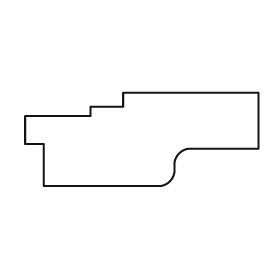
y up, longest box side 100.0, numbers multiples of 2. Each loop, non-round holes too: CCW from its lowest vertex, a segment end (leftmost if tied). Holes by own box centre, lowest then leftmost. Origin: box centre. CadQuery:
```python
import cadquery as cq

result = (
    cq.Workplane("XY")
    .moveTo(-42.0, -20.0)
    .lineTo(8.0, -20.0)
    .threePointArc((12.0, -18.0), (14.0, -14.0))
    .lineTo(14.0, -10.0)
    .threePointArc((16.0, -6.0), (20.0, -4.0))
    .lineTo(50.0, -4.0)
    .lineTo(50.0, 20.0)
    .lineTo(-8.0, 20.0)
    .lineTo(-8.0, 14.0)
    .lineTo(-22.0, 14.0)
    .lineTo(-22.0, 10.0)
    .lineTo(-50.0, 10.0)
    .lineTo(-50.0, -2.0)
    .lineTo(-42.0, -2.0)
    .close()
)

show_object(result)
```